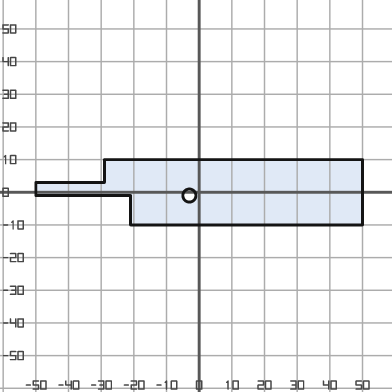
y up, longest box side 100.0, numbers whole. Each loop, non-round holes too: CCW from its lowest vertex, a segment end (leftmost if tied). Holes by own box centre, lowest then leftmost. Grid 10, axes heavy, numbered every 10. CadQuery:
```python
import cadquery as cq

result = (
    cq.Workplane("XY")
    .moveTo(-21.0, -10.0)
    .lineTo(50.0, -10.0)
    .lineTo(50.0, 10.0)
    .lineTo(-29.0, 10.0)
    .lineTo(-29.0, 3.0)
    .lineTo(-50.0, 3.0)
    .lineTo(-50.0, -1.0)
    .lineTo(-21.0, -1.0)
    .close()
    .moveTo(-3.0, -1.0)
    .circle(2.0)
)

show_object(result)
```